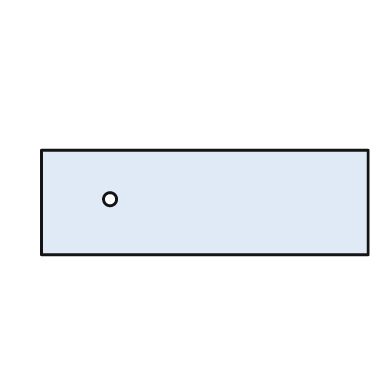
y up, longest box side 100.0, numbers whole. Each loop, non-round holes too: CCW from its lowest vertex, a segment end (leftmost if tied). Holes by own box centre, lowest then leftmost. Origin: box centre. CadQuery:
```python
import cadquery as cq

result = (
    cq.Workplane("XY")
    .moveTo(-50.0, -16.0)
    .lineTo(50.0, -16.0)
    .lineTo(50.0, 16.0)
    .lineTo(-50.0, 16.0)
    .close()
    .moveTo(-29.0, 1.0)
    .circle(2.0)
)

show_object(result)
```